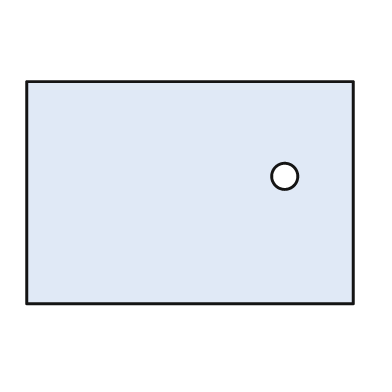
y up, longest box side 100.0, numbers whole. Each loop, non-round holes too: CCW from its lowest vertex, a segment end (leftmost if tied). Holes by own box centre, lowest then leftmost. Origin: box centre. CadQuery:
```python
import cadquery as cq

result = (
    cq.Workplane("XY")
    .moveTo(-50.0, -34.0)
    .lineTo(50.0, -34.0)
    .lineTo(50.0, 34.0)
    .lineTo(-50.0, 34.0)
    .close()
    .moveTo(29.0, 5.0)
    .circle(4.0)
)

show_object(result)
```